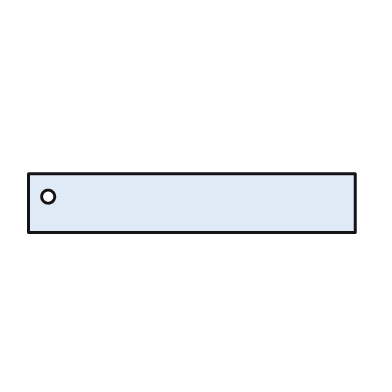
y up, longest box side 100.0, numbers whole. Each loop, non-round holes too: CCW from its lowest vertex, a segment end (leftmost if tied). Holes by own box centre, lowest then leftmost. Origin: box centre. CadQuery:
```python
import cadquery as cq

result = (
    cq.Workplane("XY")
    .moveTo(-50.0, -9.0)
    .lineTo(50.0, -9.0)
    .lineTo(50.0, 9.0)
    .lineTo(-50.0, 9.0)
    .close()
    .moveTo(-44.0, 2.0)
    .circle(2.0)
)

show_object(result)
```